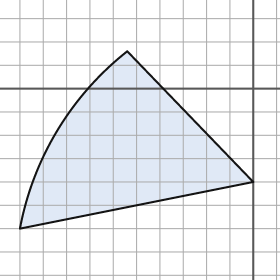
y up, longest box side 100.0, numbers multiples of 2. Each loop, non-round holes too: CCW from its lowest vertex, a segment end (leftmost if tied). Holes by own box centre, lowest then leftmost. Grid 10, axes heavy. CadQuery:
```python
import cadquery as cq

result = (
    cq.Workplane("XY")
    .moveTo(-100.0, -60.0)
    .lineTo(0.0, -40.0)
    .lineTo(-54.0, 16.0)
    .threePointArc((-84.0, -18.0), (-100.0, -60.0))
    .close()
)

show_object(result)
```